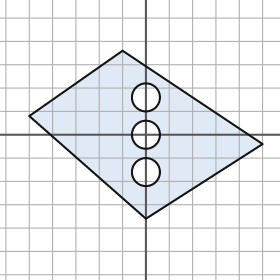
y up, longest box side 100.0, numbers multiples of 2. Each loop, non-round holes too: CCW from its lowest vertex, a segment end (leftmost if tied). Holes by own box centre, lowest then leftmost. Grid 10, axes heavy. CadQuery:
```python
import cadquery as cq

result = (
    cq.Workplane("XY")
    .moveTo(0.0, -36.0)
    .lineTo(50.0, -4.0)
    .lineTo(-10.0, 36.0)
    .lineTo(-50.0, 8.0)
    .close()
    .moveTo(0.0, -16.0)
    .circle(6.0)
    .moveTo(0.0, 0.0)
    .circle(6.0)
    .moveTo(0.0, 16.0)
    .circle(6.0)
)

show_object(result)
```